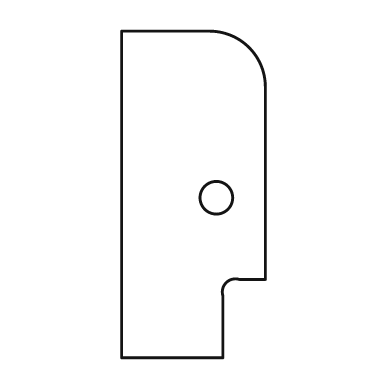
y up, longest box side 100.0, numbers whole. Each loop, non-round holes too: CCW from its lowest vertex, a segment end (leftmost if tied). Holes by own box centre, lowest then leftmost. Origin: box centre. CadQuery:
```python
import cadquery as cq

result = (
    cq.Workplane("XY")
    .moveTo(-22.0, -50.0)
    .lineTo(9.0, -50.0)
    .lineTo(9.0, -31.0)
    .threePointArc((10.0, -27.0), (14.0, -26.0))
    .lineTo(22.0, -26.0)
    .lineTo(22.0, 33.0)
    .threePointArc((17.0, 45.0), (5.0, 50.0))
    .lineTo(-22.0, 50.0)
    .close()
    .moveTo(7.0, -1.0)
    .circle(5.0)
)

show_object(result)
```